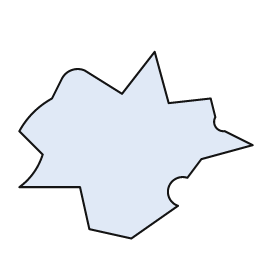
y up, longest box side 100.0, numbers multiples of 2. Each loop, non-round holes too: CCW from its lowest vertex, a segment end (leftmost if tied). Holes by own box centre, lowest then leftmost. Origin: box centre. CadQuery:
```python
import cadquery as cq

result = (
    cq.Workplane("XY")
    .moveTo(-2.0, -40.0)
    .lineTo(18.0, -26.0)
    .threePointArc((14.0, -18.0), (22.0, -14.0))
    .lineTo(28.0, -6.0)
    .lineTo(50.0, 0.0)
    .lineTo(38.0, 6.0)
    .threePointArc((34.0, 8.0), (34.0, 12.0))
    .lineTo(32.0, 20.0)
    .lineTo(14.0, 18.0)
    .lineTo(8.0, 40.0)
    .lineTo(-6.0, 22.0)
    .lineTo(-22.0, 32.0)
    .threePointArc((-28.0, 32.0), (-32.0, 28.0))
    .lineTo(-36.0, 20.0)
    .threePointArc((-44.0, 14.0), (-50.0, 6.0))
    .lineTo(-40.0, -4.0)
    .threePointArc((-44.0, -12.0), (-50.0, -18.0))
    .lineTo(-24.0, -18.0)
    .lineTo(-20.0, -36.0)
    .close()
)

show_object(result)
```